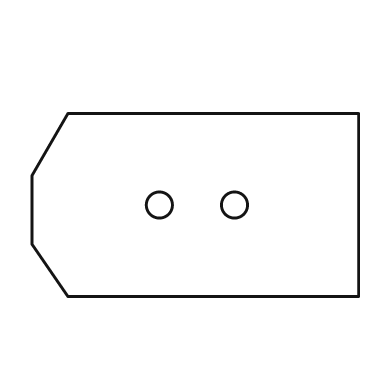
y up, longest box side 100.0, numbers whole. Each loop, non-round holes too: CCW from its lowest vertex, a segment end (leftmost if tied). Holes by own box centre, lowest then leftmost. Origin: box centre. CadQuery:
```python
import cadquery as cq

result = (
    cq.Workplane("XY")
    .moveTo(-39.0, -28.0)
    .lineTo(50.0, -28.0)
    .lineTo(50.0, 28.0)
    .lineTo(-39.0, 28.0)
    .lineTo(-50.0, 9.0)
    .lineTo(-50.0, -12.0)
    .close()
    .moveTo(-11.0, 0.0)
    .circle(4.0)
    .moveTo(12.0, 0.0)
    .circle(4.0)
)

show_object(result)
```